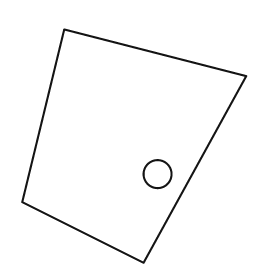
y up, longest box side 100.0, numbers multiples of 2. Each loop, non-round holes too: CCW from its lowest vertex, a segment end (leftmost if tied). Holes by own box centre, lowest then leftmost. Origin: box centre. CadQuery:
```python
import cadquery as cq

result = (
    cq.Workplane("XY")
    .moveTo(4.0, -50.0)
    .lineTo(48.0, 30.0)
    .lineTo(-30.0, 50.0)
    .lineTo(-48.0, -24.0)
    .close()
    .moveTo(10.0, -12.0)
    .circle(6.0)
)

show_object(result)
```